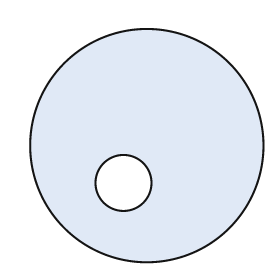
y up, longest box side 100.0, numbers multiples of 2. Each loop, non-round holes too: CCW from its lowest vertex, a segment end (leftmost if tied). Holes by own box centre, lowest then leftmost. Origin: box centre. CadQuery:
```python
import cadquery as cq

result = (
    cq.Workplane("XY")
    .moveTo(0.0, 0.0)
    .circle(50.0)
    .moveTo(-10.0, -16.0)
    .circle(12.0)
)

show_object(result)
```